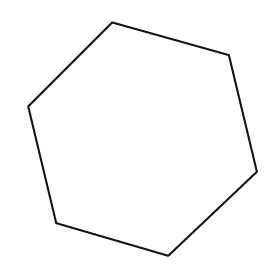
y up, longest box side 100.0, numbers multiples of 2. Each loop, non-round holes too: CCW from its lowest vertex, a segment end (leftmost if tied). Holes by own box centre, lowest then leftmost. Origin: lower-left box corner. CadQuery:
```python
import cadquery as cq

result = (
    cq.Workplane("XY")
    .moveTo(60.0, 0.0)
    .lineTo(98.0, 36.0)
    .lineTo(86.0, 86.0)
    .lineTo(36.0, 100.0)
    .lineTo(0.0, 64.0)
    .lineTo(12.0, 14.0)
    .close()
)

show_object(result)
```